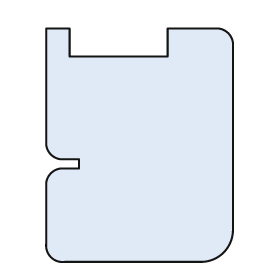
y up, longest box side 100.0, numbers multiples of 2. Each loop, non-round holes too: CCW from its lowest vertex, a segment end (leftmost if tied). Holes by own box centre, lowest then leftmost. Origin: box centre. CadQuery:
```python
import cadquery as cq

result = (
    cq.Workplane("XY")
    .moveTo(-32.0, -50.0)
    .lineTo(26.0, -50.0)
    .threePointArc((36.0, -46.0), (40.0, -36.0))
    .lineTo(40.0, 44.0)
    .threePointArc((38.0, 48.0), (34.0, 50.0))
    .lineTo(12.0, 50.0)
    .lineTo(12.0, 38.0)
    .lineTo(-30.0, 38.0)
    .lineTo(-30.0, 50.0)
    .lineTo(-40.0, 50.0)
    .lineTo(-40.0, 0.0)
    .threePointArc((-38.0, -4.0), (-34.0, -6.0))
    .lineTo(-26.0, -6.0)
    .lineTo(-26.0, -10.0)
    .lineTo(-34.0, -10.0)
    .threePointArc((-38.0, -12.0), (-40.0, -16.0))
    .lineTo(-40.0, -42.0)
    .threePointArc((-38.0, -48.0), (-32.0, -50.0))
    .close()
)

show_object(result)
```